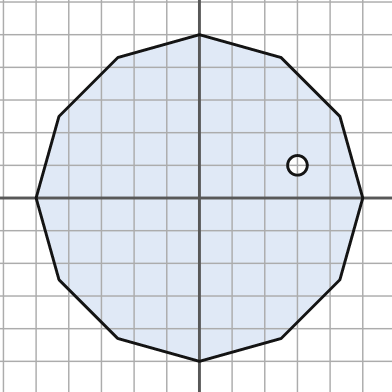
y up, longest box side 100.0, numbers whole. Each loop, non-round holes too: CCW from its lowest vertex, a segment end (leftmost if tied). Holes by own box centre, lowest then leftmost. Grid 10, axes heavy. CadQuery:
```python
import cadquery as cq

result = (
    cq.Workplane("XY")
    .moveTo(0.0, -50.0)
    .lineTo(25.0, -43.0)
    .lineTo(43.0, -25.0)
    .lineTo(50.0, 0.0)
    .lineTo(43.0, 25.0)
    .lineTo(25.0, 43.0)
    .lineTo(0.0, 50.0)
    .lineTo(-25.0, 43.0)
    .lineTo(-43.0, 25.0)
    .lineTo(-50.0, 0.0)
    .lineTo(-43.0, -25.0)
    .lineTo(-25.0, -43.0)
    .close()
    .moveTo(30.0, 10.0)
    .circle(3.0)
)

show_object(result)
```